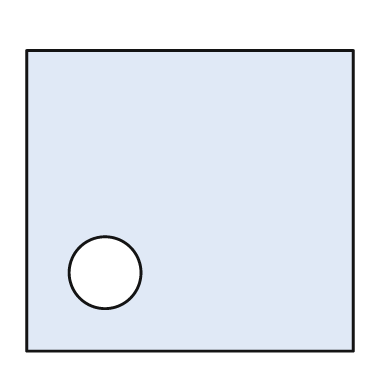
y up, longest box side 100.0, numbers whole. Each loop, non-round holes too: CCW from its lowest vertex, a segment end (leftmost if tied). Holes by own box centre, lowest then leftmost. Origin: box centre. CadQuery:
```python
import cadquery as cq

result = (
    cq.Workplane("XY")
    .moveTo(-50.0, -46.0)
    .lineTo(50.0, -46.0)
    .lineTo(50.0, 46.0)
    .lineTo(-50.0, 46.0)
    .close()
    .moveTo(-26.0, -22.0)
    .circle(11.0)
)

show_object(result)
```